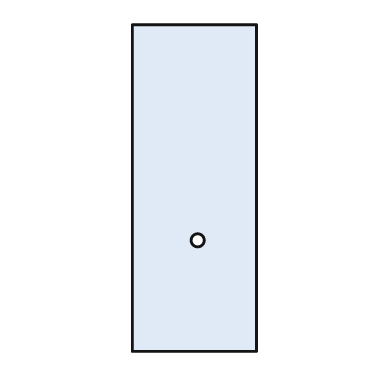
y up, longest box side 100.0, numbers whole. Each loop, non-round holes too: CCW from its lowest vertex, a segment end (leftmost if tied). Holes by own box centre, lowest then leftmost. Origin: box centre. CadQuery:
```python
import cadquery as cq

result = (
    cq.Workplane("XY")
    .moveTo(-19.0, -50.0)
    .lineTo(19.0, -50.0)
    .lineTo(19.0, 50.0)
    .lineTo(-19.0, 50.0)
    .close()
    .moveTo(1.0, -16.0)
    .circle(2.0)
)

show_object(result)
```